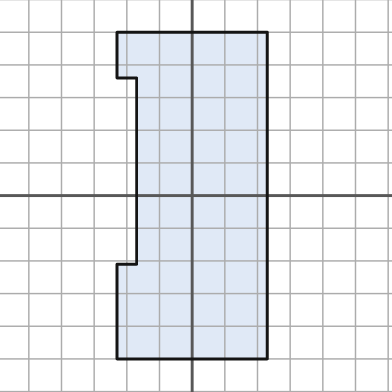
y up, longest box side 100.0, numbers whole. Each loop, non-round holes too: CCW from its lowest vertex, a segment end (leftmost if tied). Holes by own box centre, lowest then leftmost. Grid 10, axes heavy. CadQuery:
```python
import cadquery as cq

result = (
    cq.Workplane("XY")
    .moveTo(-23.0, -50.0)
    .lineTo(23.0, -50.0)
    .lineTo(23.0, 50.0)
    .lineTo(-23.0, 50.0)
    .lineTo(-23.0, 36.0)
    .lineTo(-17.0, 36.0)
    .lineTo(-17.0, -21.0)
    .lineTo(-23.0, -21.0)
    .close()
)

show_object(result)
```